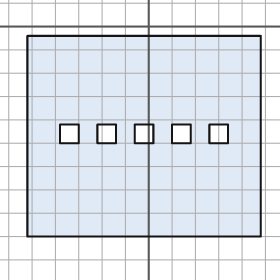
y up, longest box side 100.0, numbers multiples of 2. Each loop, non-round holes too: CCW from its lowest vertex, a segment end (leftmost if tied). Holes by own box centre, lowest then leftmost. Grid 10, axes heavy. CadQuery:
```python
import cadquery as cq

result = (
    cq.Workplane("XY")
    .moveTo(-52.0, -90.0)
    .lineTo(48.0, -90.0)
    .lineTo(48.0, -4.0)
    .lineTo(-52.0, -4.0)
    .close()
    .moveTo(-38.0, -50.0)
    .lineTo(-30.0, -50.0)
    .lineTo(-30.0, -42.0)
    .lineTo(-38.0, -42.0)
    .close()
    .moveTo(-22.0, -50.0)
    .lineTo(-14.0, -50.0)
    .lineTo(-14.0, -42.0)
    .lineTo(-22.0, -42.0)
    .close()
    .moveTo(-6.0, -50.0)
    .lineTo(2.0, -50.0)
    .lineTo(2.0, -42.0)
    .lineTo(-6.0, -42.0)
    .close()
    .moveTo(10.0, -50.0)
    .lineTo(18.0, -50.0)
    .lineTo(18.0, -42.0)
    .lineTo(10.0, -42.0)
    .close()
    .moveTo(26.0, -50.0)
    .lineTo(34.0, -50.0)
    .lineTo(34.0, -42.0)
    .lineTo(26.0, -42.0)
    .close()
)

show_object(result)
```